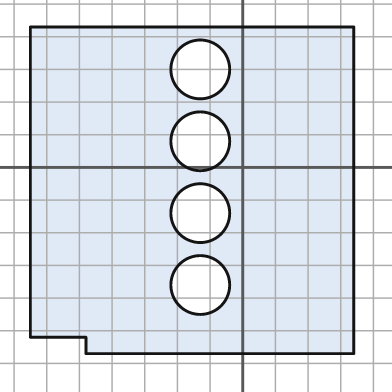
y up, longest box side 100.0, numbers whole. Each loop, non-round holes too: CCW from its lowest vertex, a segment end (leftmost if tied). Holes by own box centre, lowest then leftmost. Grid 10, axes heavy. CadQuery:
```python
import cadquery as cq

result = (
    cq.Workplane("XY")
    .moveTo(-48.0, -57.0)
    .lineTo(34.0, -57.0)
    .lineTo(34.0, 43.0)
    .lineTo(-65.0, 43.0)
    .lineTo(-65.0, -52.0)
    .lineTo(-48.0, -52.0)
    .close()
    .moveTo(-13.0, -36.0)
    .circle(9.0)
    .moveTo(-13.0, -14.0)
    .circle(9.0)
    .moveTo(-13.0, 8.0)
    .circle(9.0)
    .moveTo(-13.0, 30.0)
    .circle(9.0)
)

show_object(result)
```